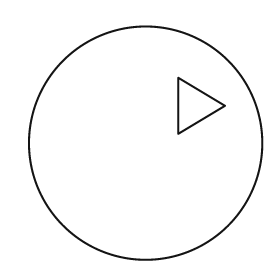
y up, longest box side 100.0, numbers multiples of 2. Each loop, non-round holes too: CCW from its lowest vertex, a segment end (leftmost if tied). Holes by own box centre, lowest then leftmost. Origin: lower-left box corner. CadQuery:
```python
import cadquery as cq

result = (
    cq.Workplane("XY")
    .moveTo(50.0, 50.0)
    .circle(50.0)
    .moveTo(64.0, 54.0)
    .lineTo(84.0, 66.0)
    .lineTo(64.0, 78.0)
    .close()
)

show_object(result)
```